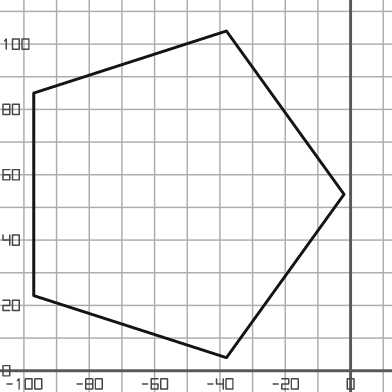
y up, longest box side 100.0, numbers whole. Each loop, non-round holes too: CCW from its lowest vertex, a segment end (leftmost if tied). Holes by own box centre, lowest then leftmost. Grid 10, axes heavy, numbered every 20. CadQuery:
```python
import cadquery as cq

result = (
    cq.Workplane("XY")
    .moveTo(-38.0, 4.0)
    .lineTo(-2.0, 54.0)
    .lineTo(-38.0, 104.0)
    .lineTo(-97.0, 85.0)
    .lineTo(-97.0, 23.0)
    .close()
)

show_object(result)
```